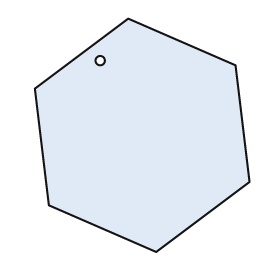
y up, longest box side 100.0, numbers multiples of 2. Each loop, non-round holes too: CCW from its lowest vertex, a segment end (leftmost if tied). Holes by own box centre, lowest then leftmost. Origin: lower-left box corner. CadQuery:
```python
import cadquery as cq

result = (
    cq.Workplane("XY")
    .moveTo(52.0, 0.0)
    .lineTo(92.0, 30.0)
    .lineTo(86.0, 80.0)
    .lineTo(40.0, 100.0)
    .lineTo(0.0, 70.0)
    .lineTo(6.0, 20.0)
    .close()
    .moveTo(28.0, 82.0)
    .circle(2.0)
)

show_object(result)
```